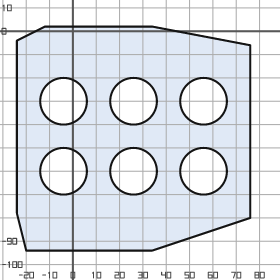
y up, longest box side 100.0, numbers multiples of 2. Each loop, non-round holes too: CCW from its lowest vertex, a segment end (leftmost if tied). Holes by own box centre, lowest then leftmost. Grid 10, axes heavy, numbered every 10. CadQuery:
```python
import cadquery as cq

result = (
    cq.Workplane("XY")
    .moveTo(-20.0, -94.0)
    .lineTo(34.0, -94.0)
    .lineTo(76.0, -80.0)
    .lineTo(76.0, -6.0)
    .lineTo(34.0, 2.0)
    .lineTo(-12.0, 2.0)
    .lineTo(-24.0, -4.0)
    .lineTo(-24.0, -78.0)
    .close()
    .moveTo(-4.0, -60.0)
    .circle(10.0)
    .moveTo(26.0, -60.0)
    .circle(10.0)
    .moveTo(56.0, -60.0)
    .circle(10.0)
    .moveTo(-4.0, -30.0)
    .circle(10.0)
    .moveTo(26.0, -30.0)
    .circle(10.0)
    .moveTo(56.0, -30.0)
    .circle(10.0)
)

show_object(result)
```